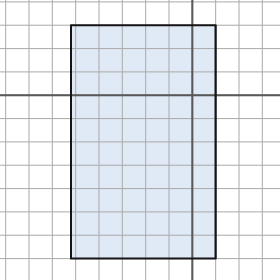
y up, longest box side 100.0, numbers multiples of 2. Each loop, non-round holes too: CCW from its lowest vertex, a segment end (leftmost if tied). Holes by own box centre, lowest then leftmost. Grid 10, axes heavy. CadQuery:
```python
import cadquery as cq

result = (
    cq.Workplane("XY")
    .moveTo(-52.0, -70.0)
    .lineTo(10.0, -70.0)
    .lineTo(10.0, 30.0)
    .lineTo(-52.0, 30.0)
    .close()
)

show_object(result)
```